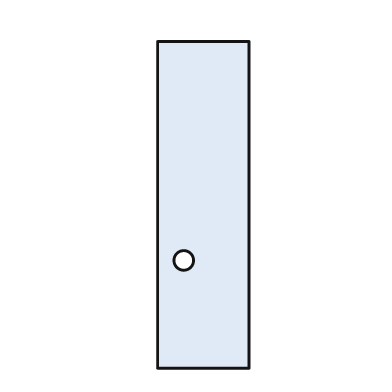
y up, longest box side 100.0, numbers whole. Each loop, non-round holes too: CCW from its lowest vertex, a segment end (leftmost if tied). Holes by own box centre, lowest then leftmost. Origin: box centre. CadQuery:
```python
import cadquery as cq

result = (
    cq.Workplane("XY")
    .moveTo(-14.0, -50.0)
    .lineTo(14.0, -50.0)
    .lineTo(14.0, 50.0)
    .lineTo(-14.0, 50.0)
    .close()
    .moveTo(-6.0, -17.0)
    .circle(3.0)
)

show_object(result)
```